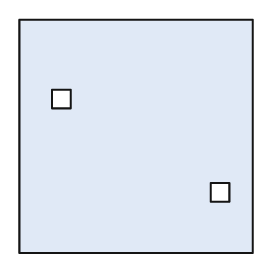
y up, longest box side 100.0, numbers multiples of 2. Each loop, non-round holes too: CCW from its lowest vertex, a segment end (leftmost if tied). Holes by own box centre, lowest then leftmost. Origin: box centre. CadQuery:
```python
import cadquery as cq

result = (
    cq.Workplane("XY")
    .moveTo(-50.0, -50.0)
    .lineTo(50.0, -50.0)
    .lineTo(50.0, 50.0)
    .lineTo(-50.0, 50.0)
    .close()
    .moveTo(32.0, -28.0)
    .lineTo(40.0, -28.0)
    .lineTo(40.0, -20.0)
    .lineTo(32.0, -20.0)
    .close()
    .moveTo(-36.0, 12.0)
    .lineTo(-28.0, 12.0)
    .lineTo(-28.0, 20.0)
    .lineTo(-36.0, 20.0)
    .close()
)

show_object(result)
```